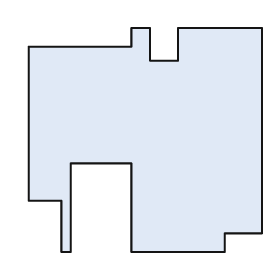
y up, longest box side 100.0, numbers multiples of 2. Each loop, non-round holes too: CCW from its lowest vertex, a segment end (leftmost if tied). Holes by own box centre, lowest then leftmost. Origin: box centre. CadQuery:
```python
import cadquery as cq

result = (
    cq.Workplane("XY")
    .moveTo(-36.0, -48.0)
    .lineTo(-32.0, -48.0)
    .lineTo(-32.0, -10.0)
    .lineTo(-6.0, -10.0)
    .lineTo(-6.0, -48.0)
    .lineTo(34.0, -48.0)
    .lineTo(34.0, -40.0)
    .lineTo(50.0, -40.0)
    .lineTo(50.0, 48.0)
    .lineTo(14.0, 48.0)
    .lineTo(14.0, 34.0)
    .lineTo(2.0, 34.0)
    .lineTo(2.0, 48.0)
    .lineTo(-6.0, 48.0)
    .lineTo(-6.0, 40.0)
    .lineTo(-50.0, 40.0)
    .lineTo(-50.0, -26.0)
    .lineTo(-36.0, -26.0)
    .close()
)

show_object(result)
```